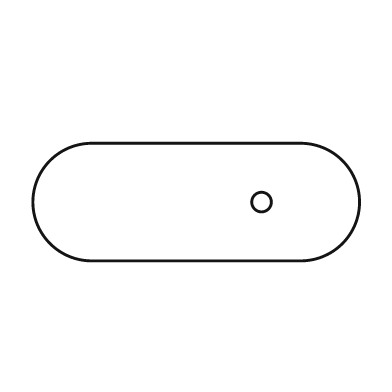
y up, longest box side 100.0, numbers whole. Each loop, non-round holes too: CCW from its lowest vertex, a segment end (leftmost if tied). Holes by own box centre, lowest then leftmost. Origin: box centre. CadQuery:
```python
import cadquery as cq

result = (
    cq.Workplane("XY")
    .moveTo(-32.0, -18.0)
    .lineTo(32.0, -18.0)
    .threePointArc((50.0, 0.0), (32.0, 18.0))
    .lineTo(-32.0, 18.0)
    .threePointArc((-50.0, 0.0), (-32.0, -18.0))
    .close()
    .moveTo(20.0, 0.0)
    .circle(3.0)
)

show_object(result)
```